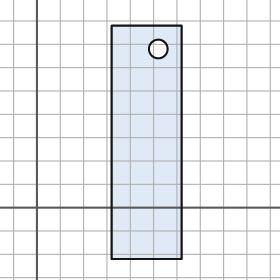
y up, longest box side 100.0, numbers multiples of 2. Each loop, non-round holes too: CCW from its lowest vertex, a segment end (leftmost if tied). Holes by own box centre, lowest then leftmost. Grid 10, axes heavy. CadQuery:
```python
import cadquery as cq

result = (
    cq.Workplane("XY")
    .moveTo(32.0, -22.0)
    .lineTo(62.0, -22.0)
    .lineTo(62.0, 78.0)
    .lineTo(32.0, 78.0)
    .close()
    .moveTo(52.0, 68.0)
    .circle(4.0)
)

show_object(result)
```